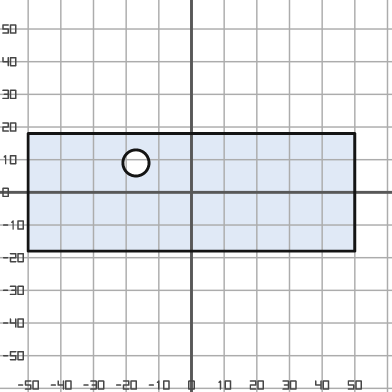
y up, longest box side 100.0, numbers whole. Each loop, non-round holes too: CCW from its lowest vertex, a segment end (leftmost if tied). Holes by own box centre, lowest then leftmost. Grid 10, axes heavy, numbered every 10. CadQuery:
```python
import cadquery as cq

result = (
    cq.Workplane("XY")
    .moveTo(-50.0, -18.0)
    .lineTo(50.0, -18.0)
    .lineTo(50.0, 18.0)
    .lineTo(-50.0, 18.0)
    .close()
    .moveTo(-17.0, 9.0)
    .circle(4.0)
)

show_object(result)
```